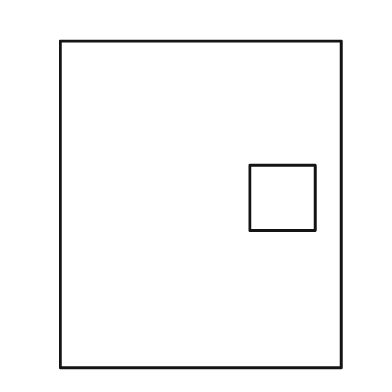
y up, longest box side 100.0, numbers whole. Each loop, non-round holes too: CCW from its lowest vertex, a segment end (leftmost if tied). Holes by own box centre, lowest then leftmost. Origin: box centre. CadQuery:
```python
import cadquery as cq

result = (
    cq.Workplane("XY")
    .moveTo(-43.0, -50.0)
    .lineTo(43.0, -50.0)
    .lineTo(43.0, 50.0)
    .lineTo(-43.0, 50.0)
    .close()
    .moveTo(15.0, -8.0)
    .lineTo(35.0, -8.0)
    .lineTo(35.0, 12.0)
    .lineTo(15.0, 12.0)
    .close()
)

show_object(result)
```